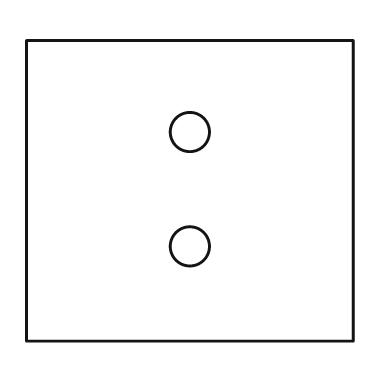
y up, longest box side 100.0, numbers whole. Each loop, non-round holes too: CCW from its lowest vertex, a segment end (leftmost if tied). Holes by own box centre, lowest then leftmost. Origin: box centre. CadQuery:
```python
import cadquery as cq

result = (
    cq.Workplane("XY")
    .moveTo(-50.0, -46.0)
    .lineTo(50.0, -46.0)
    .lineTo(50.0, 46.0)
    .lineTo(-50.0, 46.0)
    .close()
    .moveTo(0.0, -17.0)
    .circle(6.0)
    .moveTo(0.0, 18.0)
    .circle(6.0)
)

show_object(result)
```